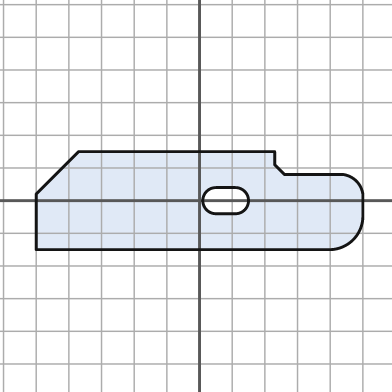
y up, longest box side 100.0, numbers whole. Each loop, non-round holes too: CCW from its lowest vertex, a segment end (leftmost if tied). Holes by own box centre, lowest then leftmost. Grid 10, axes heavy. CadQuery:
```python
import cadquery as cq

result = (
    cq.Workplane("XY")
    .moveTo(-50.0, -15.0)
    .lineTo(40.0, -15.0)
    .threePointArc((47.0, -12.0), (50.0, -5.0))
    .lineTo(50.0, 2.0)
    .threePointArc((48.0, 6.0), (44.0, 8.0))
    .lineTo(26.0, 8.0)
    .lineTo(23.0, 11.0)
    .lineTo(23.0, 15.0)
    .lineTo(-37.0, 15.0)
    .lineTo(-50.0, 2.0)
    .close()
    .moveTo(5.0, -4.0)
    .lineTo(11.0, -4.0)
    .threePointArc((15.0, 0.0), (11.0, 4.0))
    .lineTo(5.0, 4.0)
    .threePointArc((1.0, 0.0), (5.0, -4.0))
    .close()
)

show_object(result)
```